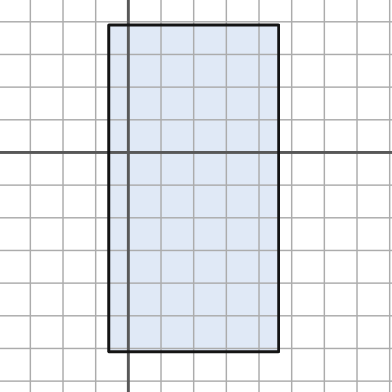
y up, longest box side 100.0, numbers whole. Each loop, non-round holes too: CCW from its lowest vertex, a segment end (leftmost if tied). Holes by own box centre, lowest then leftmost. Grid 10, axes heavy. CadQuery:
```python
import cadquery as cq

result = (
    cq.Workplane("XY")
    .moveTo(-6.0, -61.0)
    .lineTo(46.0, -61.0)
    .lineTo(46.0, 39.0)
    .lineTo(-6.0, 39.0)
    .close()
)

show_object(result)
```